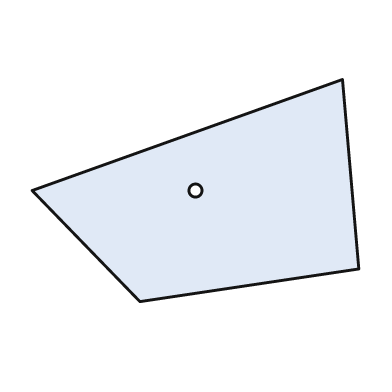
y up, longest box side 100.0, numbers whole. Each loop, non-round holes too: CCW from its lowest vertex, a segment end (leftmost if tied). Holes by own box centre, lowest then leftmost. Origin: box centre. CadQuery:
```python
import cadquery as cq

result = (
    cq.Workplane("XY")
    .moveTo(-17.0, -34.0)
    .lineTo(50.0, -24.0)
    .lineTo(45.0, 34.0)
    .lineTo(-50.0, 0.0)
    .close()
    .moveTo(0.0, 0.0)
    .circle(2.0)
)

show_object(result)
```